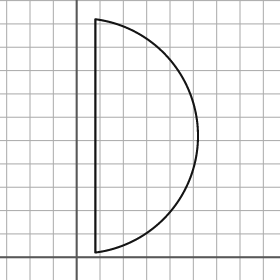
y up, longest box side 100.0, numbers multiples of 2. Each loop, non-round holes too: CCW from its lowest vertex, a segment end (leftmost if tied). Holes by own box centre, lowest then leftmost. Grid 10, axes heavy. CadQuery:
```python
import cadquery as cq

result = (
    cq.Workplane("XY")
    .moveTo(8.0, 2.0)
    .threePointArc((52.0, 52.0), (8.0, 102.0))
    .close()
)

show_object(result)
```